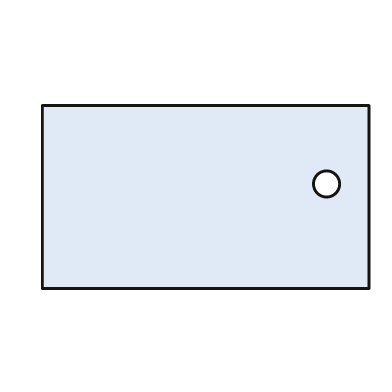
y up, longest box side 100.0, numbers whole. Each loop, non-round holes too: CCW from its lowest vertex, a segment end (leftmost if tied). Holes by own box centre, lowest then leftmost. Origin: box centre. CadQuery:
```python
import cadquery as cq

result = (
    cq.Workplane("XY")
    .moveTo(-50.0, -28.0)
    .lineTo(50.0, -28.0)
    .lineTo(50.0, 28.0)
    .lineTo(-50.0, 28.0)
    .close()
    .moveTo(37.0, 4.0)
    .circle(4.0)
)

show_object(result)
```